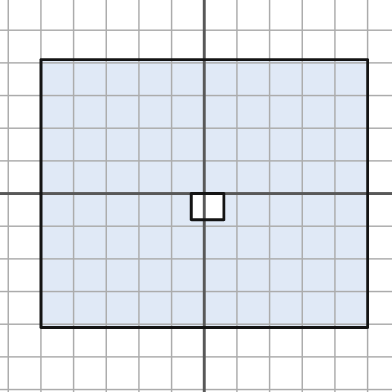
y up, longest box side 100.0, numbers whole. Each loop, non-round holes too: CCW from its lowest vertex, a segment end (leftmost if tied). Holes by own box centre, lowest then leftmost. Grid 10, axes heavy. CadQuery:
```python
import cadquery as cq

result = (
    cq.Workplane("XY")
    .moveTo(-50.0, -41.0)
    .lineTo(50.0, -41.0)
    .lineTo(50.0, 41.0)
    .lineTo(-50.0, 41.0)
    .close()
    .moveTo(-4.0, -8.0)
    .lineTo(6.0, -8.0)
    .lineTo(6.0, 0.0)
    .lineTo(-4.0, 0.0)
    .close()
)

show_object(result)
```